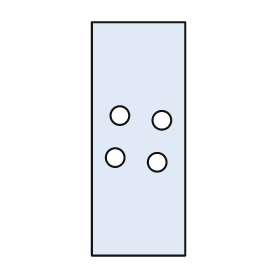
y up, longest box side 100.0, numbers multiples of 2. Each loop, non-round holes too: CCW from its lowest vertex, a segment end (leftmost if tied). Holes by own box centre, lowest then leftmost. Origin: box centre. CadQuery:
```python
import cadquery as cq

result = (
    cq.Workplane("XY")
    .moveTo(-20.0, -50.0)
    .lineTo(20.0, -50.0)
    .lineTo(20.0, 50.0)
    .lineTo(-20.0, 50.0)
    .close()
    .moveTo(8.0, -10.0)
    .circle(4.0)
    .moveTo(-10.0, -8.0)
    .circle(4.0)
    .moveTo(10.0, 8.0)
    .circle(4.0)
    .moveTo(-8.0, 10.0)
    .circle(4.0)
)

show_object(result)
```